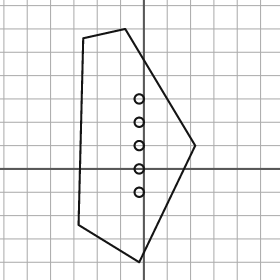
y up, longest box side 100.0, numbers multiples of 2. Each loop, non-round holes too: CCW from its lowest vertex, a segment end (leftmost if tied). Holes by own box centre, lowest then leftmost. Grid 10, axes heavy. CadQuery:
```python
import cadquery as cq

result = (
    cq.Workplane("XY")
    .moveTo(-2.0, -40.0)
    .lineTo(22.0, 10.0)
    .lineTo(-8.0, 60.0)
    .lineTo(-26.0, 56.0)
    .lineTo(-28.0, -24.0)
    .close()
    .moveTo(-2.0, -10.0)
    .circle(2.0)
    .moveTo(-2.0, 0.0)
    .circle(2.0)
    .moveTo(-2.0, 10.0)
    .circle(2.0)
    .moveTo(-2.0, 20.0)
    .circle(2.0)
    .moveTo(-2.0, 30.0)
    .circle(2.0)
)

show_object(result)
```